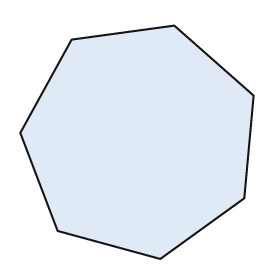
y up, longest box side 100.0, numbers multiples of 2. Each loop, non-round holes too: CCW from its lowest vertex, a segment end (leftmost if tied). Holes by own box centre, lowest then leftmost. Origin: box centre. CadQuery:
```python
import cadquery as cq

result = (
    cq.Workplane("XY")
    .moveTo(10.0, -50.0)
    .lineTo(46.0, -24.0)
    .lineTo(50.0, 20.0)
    .lineTo(16.0, 50.0)
    .lineTo(-28.0, 44.0)
    .lineTo(-50.0, 4.0)
    .lineTo(-34.0, -38.0)
    .close()
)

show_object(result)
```